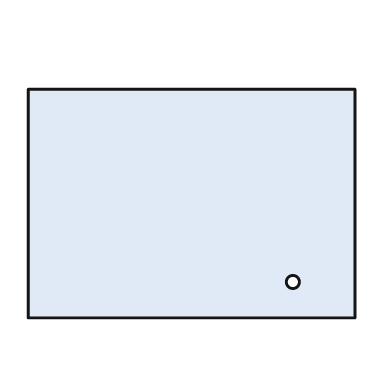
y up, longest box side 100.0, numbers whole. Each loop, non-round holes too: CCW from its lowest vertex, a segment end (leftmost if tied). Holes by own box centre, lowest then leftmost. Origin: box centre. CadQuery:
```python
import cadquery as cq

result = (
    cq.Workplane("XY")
    .moveTo(-50.0, -35.0)
    .lineTo(50.0, -35.0)
    .lineTo(50.0, 35.0)
    .lineTo(-50.0, 35.0)
    .close()
    .moveTo(31.0, -24.0)
    .circle(2.0)
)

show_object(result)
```